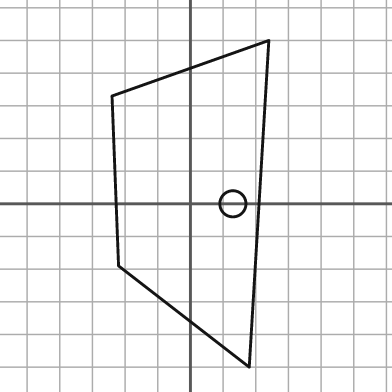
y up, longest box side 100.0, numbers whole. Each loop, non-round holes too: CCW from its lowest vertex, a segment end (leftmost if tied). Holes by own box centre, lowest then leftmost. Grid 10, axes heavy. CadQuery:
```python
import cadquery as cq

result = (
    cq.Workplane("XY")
    .moveTo(18.0, -50.0)
    .lineTo(24.0, 50.0)
    .lineTo(-24.0, 33.0)
    .lineTo(-22.0, -19.0)
    .close()
    .moveTo(13.0, 0.0)
    .circle(4.0)
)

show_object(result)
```